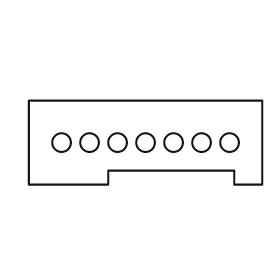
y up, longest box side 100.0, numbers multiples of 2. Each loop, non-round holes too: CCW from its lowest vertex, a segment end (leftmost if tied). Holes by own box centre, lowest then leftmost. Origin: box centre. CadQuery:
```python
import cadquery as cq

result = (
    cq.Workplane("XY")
    .moveTo(-50.0, -18.0)
    .lineTo(-16.0, -18.0)
    .lineTo(-16.0, -12.0)
    .lineTo(38.0, -12.0)
    .lineTo(38.0, -18.0)
    .lineTo(50.0, -18.0)
    .lineTo(50.0, 18.0)
    .lineTo(-50.0, 18.0)
    .close()
    .moveTo(-36.0, 0.0)
    .circle(4.0)
    .moveTo(-24.0, 0.0)
    .circle(4.0)
    .moveTo(-12.0, 0.0)
    .circle(4.0)
    .moveTo(0.0, 0.0)
    .circle(4.0)
    .moveTo(12.0, 0.0)
    .circle(4.0)
    .moveTo(24.0, 0.0)
    .circle(4.0)
    .moveTo(36.0, 0.0)
    .circle(4.0)
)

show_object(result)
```